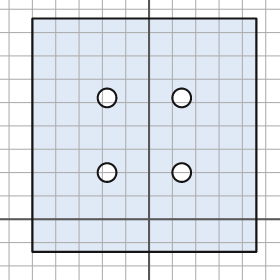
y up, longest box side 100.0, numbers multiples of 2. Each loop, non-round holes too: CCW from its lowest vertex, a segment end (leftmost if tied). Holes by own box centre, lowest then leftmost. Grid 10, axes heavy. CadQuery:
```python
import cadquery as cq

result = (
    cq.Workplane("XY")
    .moveTo(-50.0, -14.0)
    .lineTo(46.0, -14.0)
    .lineTo(46.0, 86.0)
    .lineTo(-50.0, 86.0)
    .close()
    .moveTo(-18.0, 20.0)
    .circle(4.0)
    .moveTo(14.0, 20.0)
    .circle(4.0)
    .moveTo(-18.0, 52.0)
    .circle(4.0)
    .moveTo(14.0, 52.0)
    .circle(4.0)
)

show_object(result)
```